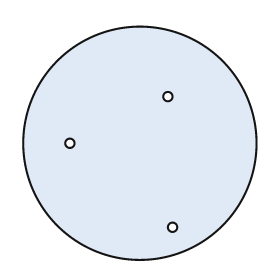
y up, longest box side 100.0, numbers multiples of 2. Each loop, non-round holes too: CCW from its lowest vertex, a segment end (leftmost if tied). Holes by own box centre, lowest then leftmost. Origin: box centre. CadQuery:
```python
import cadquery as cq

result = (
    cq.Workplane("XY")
    .moveTo(0.0, 0.0)
    .circle(50.0)
    .moveTo(14.0, -36.0)
    .circle(2.0)
    .moveTo(-30.0, 0.0)
    .circle(2.0)
    .moveTo(12.0, 20.0)
    .circle(2.0)
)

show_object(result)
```